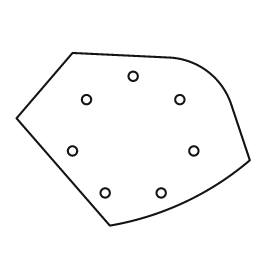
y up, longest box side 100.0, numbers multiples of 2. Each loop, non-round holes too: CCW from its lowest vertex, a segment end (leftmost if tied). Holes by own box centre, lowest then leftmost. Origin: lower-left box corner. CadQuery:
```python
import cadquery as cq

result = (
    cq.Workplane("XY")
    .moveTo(40.0, 0.0)
    .threePointArc((72.0, 10.0), (100.0, 28.0))
    .lineTo(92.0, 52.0)
    .threePointArc((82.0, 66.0), (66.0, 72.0))
    .lineTo(24.0, 74.0)
    .lineTo(0.0, 46.0)
    .close()
    .moveTo(38.0, 14.0)
    .circle(2.0)
    .moveTo(62.0, 14.0)
    .circle(2.0)
    .moveTo(24.0, 32.0)
    .circle(2.0)
    .moveTo(76.0, 32.0)
    .circle(2.0)
    .moveTo(30.0, 54.0)
    .circle(2.0)
    .moveTo(70.0, 54.0)
    .circle(2.0)
    .moveTo(50.0, 64.0)
    .circle(2.0)
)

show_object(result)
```